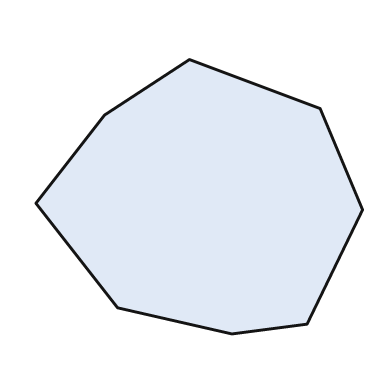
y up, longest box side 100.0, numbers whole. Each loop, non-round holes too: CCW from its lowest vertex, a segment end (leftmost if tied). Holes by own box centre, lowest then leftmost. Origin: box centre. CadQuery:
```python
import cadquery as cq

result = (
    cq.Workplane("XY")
    .moveTo(10.0, -42.0)
    .lineTo(33.0, -39.0)
    .lineTo(50.0, -4.0)
    .lineTo(37.0, 27.0)
    .lineTo(-3.0, 42.0)
    .lineTo(-29.0, 25.0)
    .lineTo(-50.0, -2.0)
    .lineTo(-25.0, -34.0)
    .close()
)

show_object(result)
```